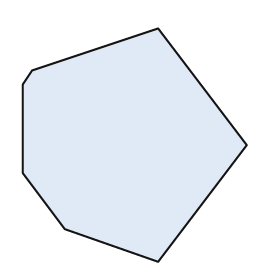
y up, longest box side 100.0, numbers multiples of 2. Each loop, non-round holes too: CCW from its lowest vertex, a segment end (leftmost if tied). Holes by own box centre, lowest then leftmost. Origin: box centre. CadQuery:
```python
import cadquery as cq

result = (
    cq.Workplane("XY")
    .moveTo(10.0, -50.0)
    .lineTo(48.0, 0.0)
    .lineTo(10.0, 50.0)
    .lineTo(-44.0, 32.0)
    .lineTo(-48.0, 26.0)
    .lineTo(-48.0, -12.0)
    .lineTo(-30.0, -36.0)
    .close()
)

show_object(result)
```